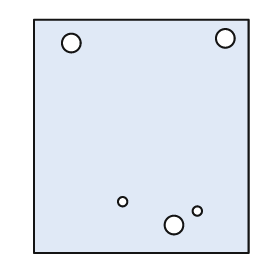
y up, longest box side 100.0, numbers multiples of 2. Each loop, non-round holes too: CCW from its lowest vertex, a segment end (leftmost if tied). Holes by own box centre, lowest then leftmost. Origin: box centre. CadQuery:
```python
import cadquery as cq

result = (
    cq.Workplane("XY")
    .moveTo(-46.0, -50.0)
    .lineTo(46.0, -50.0)
    .lineTo(46.0, 50.0)
    .lineTo(-46.0, 50.0)
    .close()
    .moveTo(14.0, -38.0)
    .circle(4.0)
    .moveTo(24.0, -32.0)
    .circle(2.0)
    .moveTo(-8.0, -28.0)
    .circle(2.0)
    .moveTo(-30.0, 40.0)
    .circle(4.0)
    .moveTo(36.0, 42.0)
    .circle(4.0)
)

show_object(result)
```